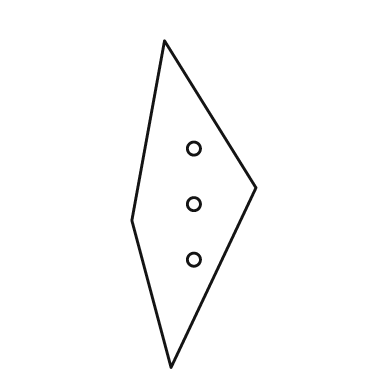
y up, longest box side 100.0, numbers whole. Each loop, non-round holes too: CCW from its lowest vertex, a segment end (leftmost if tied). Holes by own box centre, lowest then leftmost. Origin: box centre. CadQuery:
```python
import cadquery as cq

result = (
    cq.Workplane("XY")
    .moveTo(-7.0, -50.0)
    .lineTo(19.0, 5.0)
    .lineTo(-9.0, 50.0)
    .lineTo(-19.0, -5.0)
    .close()
    .moveTo(0.0, -17.0)
    .circle(2.0)
    .moveTo(0.0, 0.0)
    .circle(2.0)
    .moveTo(0.0, 17.0)
    .circle(2.0)
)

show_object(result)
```